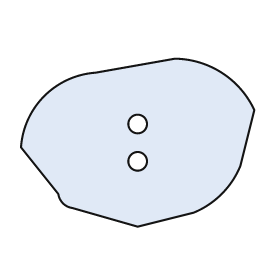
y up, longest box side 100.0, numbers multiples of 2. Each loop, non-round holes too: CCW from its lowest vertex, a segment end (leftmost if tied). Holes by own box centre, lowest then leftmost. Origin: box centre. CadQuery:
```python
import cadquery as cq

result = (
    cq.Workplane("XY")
    .moveTo(0.0, -36.0)
    .lineTo(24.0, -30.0)
    .threePointArc((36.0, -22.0), (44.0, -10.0))
    .lineTo(50.0, 14.0)
    .threePointArc((36.0, 30.0), (16.0, 36.0))
    .lineTo(-18.0, 30.0)
    .threePointArc((-40.0, 20.0), (-50.0, -2.0))
    .lineTo(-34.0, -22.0)
    .threePointArc((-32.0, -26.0), (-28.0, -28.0))
    .close()
    .moveTo(0.0, -8.0)
    .circle(4.0)
    .moveTo(0.0, 8.0)
    .circle(4.0)
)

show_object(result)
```